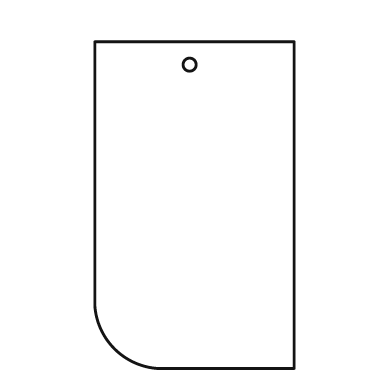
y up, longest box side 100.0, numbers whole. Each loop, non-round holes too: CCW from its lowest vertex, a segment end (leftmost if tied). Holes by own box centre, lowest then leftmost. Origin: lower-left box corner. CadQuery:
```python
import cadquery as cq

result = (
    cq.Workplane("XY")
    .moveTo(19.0, 0.0)
    .lineTo(61.0, 0.0)
    .lineTo(61.0, 100.0)
    .lineTo(0.0, 100.0)
    .lineTo(0.0, 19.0)
    .threePointArc((6.0, 6.0), (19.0, 0.0))
    .close()
    .moveTo(29.0, 93.0)
    .circle(2.0)
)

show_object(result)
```